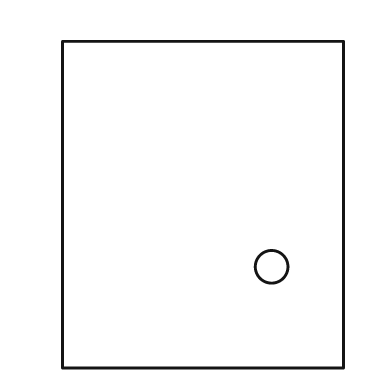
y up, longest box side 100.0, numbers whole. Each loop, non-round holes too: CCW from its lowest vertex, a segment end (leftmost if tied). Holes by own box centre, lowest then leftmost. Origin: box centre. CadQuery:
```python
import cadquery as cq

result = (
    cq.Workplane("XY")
    .moveTo(-43.0, -50.0)
    .lineTo(43.0, -50.0)
    .lineTo(43.0, 50.0)
    .lineTo(-43.0, 50.0)
    .close()
    .moveTo(21.0, -19.0)
    .circle(5.0)
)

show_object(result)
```